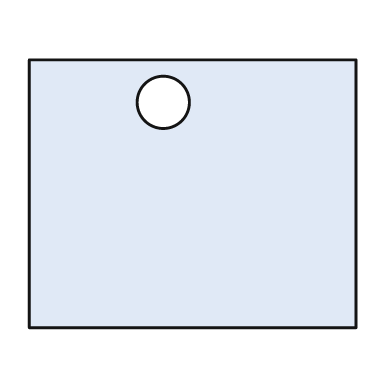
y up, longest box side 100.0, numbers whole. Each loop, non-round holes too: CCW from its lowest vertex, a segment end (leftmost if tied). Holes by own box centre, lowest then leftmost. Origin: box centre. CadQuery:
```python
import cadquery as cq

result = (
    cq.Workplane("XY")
    .moveTo(-50.0, -41.0)
    .lineTo(50.0, -41.0)
    .lineTo(50.0, 41.0)
    .lineTo(-50.0, 41.0)
    .close()
    .moveTo(-9.0, 28.0)
    .circle(8.0)
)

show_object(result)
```